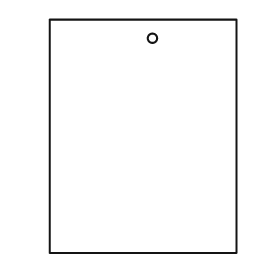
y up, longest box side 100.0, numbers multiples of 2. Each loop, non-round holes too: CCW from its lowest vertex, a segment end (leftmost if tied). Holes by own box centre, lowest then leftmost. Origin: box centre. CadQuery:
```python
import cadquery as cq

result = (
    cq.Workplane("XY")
    .moveTo(-40.0, -50.0)
    .lineTo(40.0, -50.0)
    .lineTo(40.0, 50.0)
    .lineTo(-40.0, 50.0)
    .close()
    .moveTo(4.0, 42.0)
    .circle(2.0)
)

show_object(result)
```